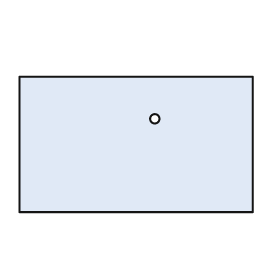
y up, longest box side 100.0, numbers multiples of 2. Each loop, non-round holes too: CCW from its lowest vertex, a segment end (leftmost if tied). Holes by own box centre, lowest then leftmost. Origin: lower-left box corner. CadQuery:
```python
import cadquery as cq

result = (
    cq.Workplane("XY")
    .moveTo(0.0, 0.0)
    .lineTo(100.0, 0.0)
    .lineTo(100.0, 58.0)
    .lineTo(0.0, 58.0)
    .close()
    .moveTo(58.0, 40.0)
    .circle(2.0)
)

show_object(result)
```